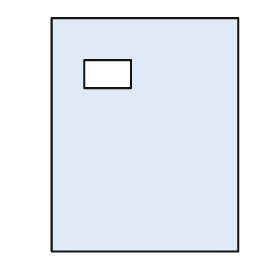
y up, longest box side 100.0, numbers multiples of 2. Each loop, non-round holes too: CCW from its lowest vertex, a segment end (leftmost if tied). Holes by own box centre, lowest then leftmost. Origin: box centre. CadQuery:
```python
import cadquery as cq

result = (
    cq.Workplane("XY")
    .moveTo(-40.0, -50.0)
    .lineTo(40.0, -50.0)
    .lineTo(40.0, 50.0)
    .lineTo(-40.0, 50.0)
    .close()
    .moveTo(-26.0, 20.0)
    .lineTo(-6.0, 20.0)
    .lineTo(-6.0, 32.0)
    .lineTo(-26.0, 32.0)
    .close()
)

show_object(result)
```